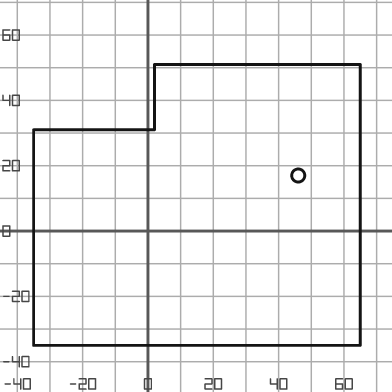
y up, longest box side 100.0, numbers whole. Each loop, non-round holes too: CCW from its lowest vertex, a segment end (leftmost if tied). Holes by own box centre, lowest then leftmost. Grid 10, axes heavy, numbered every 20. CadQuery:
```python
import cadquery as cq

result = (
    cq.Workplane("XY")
    .moveTo(-35.0, -35.0)
    .lineTo(65.0, -35.0)
    .lineTo(65.0, 51.0)
    .lineTo(2.0, 51.0)
    .lineTo(2.0, 31.0)
    .lineTo(-35.0, 31.0)
    .close()
    .moveTo(46.0, 17.0)
    .circle(2.0)
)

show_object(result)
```